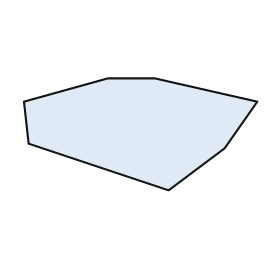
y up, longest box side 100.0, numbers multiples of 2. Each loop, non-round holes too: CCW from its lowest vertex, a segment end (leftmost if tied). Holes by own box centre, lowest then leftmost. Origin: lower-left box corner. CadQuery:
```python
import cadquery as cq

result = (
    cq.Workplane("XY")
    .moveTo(62.0, 0.0)
    .lineTo(86.0, 18.0)
    .lineTo(100.0, 38.0)
    .lineTo(56.0, 48.0)
    .lineTo(36.0, 48.0)
    .lineTo(0.0, 38.0)
    .lineTo(2.0, 20.0)
    .close()
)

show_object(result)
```